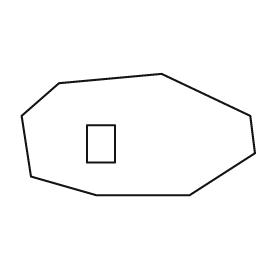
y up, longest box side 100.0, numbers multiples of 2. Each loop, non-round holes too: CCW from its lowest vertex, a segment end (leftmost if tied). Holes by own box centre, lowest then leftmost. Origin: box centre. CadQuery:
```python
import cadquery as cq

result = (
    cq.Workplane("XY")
    .moveTo(-18.0, -26.0)
    .lineTo(22.0, -26.0)
    .lineTo(50.0, -8.0)
    .lineTo(48.0, 8.0)
    .lineTo(10.0, 26.0)
    .lineTo(-34.0, 22.0)
    .lineTo(-50.0, 8.0)
    .lineTo(-46.0, -18.0)
    .close()
    .moveTo(-22.0, -12.0)
    .lineTo(-10.0, -12.0)
    .lineTo(-10.0, 4.0)
    .lineTo(-22.0, 4.0)
    .close()
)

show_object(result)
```